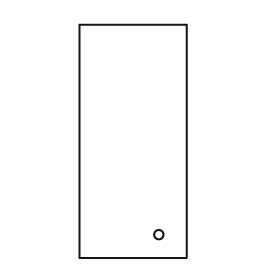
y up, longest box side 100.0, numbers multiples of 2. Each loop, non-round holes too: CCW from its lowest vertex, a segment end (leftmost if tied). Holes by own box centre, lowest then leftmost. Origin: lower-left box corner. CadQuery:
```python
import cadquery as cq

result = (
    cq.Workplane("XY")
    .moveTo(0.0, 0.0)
    .lineTo(46.0, 0.0)
    .lineTo(46.0, 100.0)
    .lineTo(0.0, 100.0)
    .close()
    .moveTo(34.0, 10.0)
    .circle(2.0)
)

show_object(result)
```